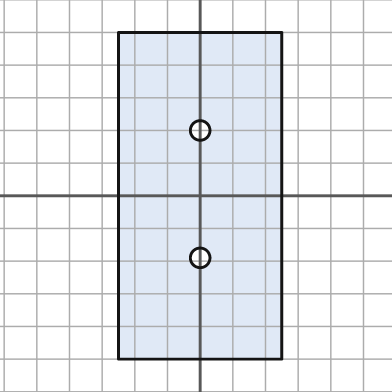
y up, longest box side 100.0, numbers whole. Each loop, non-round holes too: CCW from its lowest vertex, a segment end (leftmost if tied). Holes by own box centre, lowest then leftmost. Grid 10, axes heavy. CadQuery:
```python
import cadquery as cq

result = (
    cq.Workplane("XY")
    .moveTo(-25.0, -50.0)
    .lineTo(25.0, -50.0)
    .lineTo(25.0, 50.0)
    .lineTo(-25.0, 50.0)
    .close()
    .moveTo(0.0, -19.0)
    .circle(3.0)
    .moveTo(0.0, 20.0)
    .circle(3.0)
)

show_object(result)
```